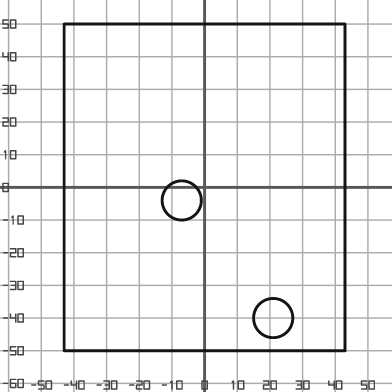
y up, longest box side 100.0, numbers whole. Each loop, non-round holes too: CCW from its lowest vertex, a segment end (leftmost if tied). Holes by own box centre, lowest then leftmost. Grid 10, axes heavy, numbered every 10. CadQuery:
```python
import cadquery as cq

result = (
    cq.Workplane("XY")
    .moveTo(-43.0, -50.0)
    .lineTo(43.0, -50.0)
    .lineTo(43.0, 50.0)
    .lineTo(-43.0, 50.0)
    .close()
    .moveTo(21.0, -40.0)
    .circle(6.0)
    .moveTo(-7.0, -4.0)
    .circle(6.0)
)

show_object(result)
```